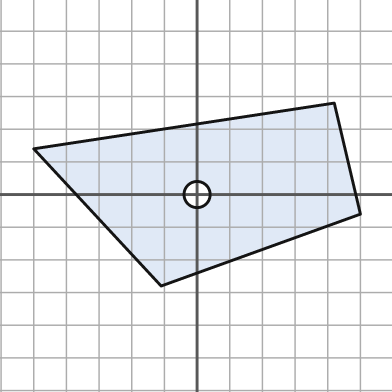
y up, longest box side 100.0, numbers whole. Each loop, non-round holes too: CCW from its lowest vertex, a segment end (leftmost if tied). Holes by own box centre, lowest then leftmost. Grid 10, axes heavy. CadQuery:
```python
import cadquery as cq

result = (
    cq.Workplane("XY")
    .moveTo(-11.0, -28.0)
    .lineTo(50.0, -6.0)
    .lineTo(42.0, 28.0)
    .lineTo(-50.0, 14.0)
    .close()
    .moveTo(0.0, 0.0)
    .circle(4.0)
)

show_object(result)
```